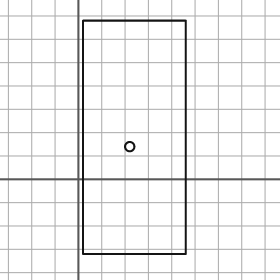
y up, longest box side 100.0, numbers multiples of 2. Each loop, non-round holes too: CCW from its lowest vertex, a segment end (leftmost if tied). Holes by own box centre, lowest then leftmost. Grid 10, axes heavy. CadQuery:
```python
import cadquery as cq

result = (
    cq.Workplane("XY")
    .moveTo(2.0, -32.0)
    .lineTo(46.0, -32.0)
    .lineTo(46.0, 68.0)
    .lineTo(2.0, 68.0)
    .close()
    .moveTo(22.0, 14.0)
    .circle(2.0)
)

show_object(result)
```